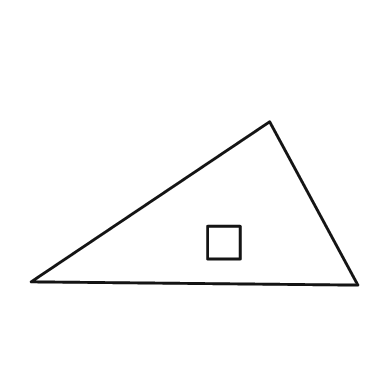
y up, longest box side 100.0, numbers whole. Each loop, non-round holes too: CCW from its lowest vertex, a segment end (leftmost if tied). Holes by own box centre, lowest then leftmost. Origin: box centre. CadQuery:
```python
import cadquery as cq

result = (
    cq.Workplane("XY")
    .moveTo(50.0, -25.0)
    .lineTo(23.0, 25.0)
    .lineTo(-50.0, -24.0)
    .close()
    .moveTo(4.0, -17.0)
    .lineTo(14.0, -17.0)
    .lineTo(14.0, -7.0)
    .lineTo(4.0, -7.0)
    .close()
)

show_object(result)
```